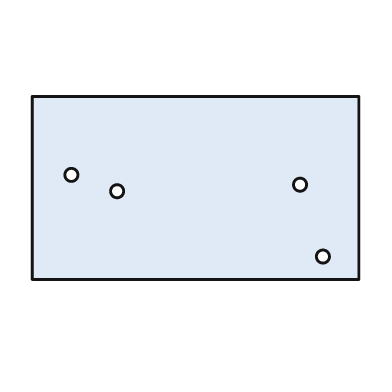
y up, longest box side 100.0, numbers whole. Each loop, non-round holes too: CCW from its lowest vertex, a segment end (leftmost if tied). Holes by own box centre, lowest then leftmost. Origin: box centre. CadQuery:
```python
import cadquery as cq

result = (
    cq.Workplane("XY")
    .moveTo(-50.0, -28.0)
    .lineTo(50.0, -28.0)
    .lineTo(50.0, 28.0)
    .lineTo(-50.0, 28.0)
    .close()
    .moveTo(39.0, -21.0)
    .circle(2.0)
    .moveTo(-24.0, -1.0)
    .circle(2.0)
    .moveTo(32.0, 1.0)
    .circle(2.0)
    .moveTo(-38.0, 4.0)
    .circle(2.0)
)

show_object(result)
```